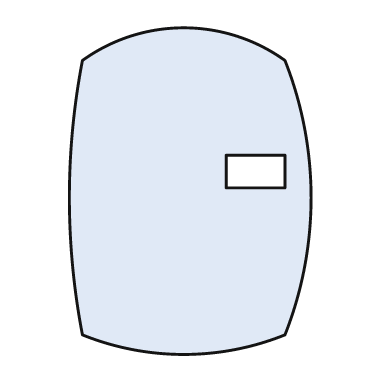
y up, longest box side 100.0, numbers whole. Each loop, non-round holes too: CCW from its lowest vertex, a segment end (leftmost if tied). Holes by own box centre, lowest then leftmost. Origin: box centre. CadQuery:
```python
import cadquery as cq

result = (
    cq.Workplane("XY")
    .moveTo(-33.0, -44.0)
    .threePointArc((-2.0, -50.0), (29.0, -44.0))
    .threePointArc((37.0, -2.0), (29.0, 40.0))
    .threePointArc((-2.0, 50.0), (-33.0, 40.0))
    .threePointArc((-37.0, -2.0), (-33.0, -44.0))
    .close()
    .moveTo(11.0, 1.0)
    .lineTo(29.0, 1.0)
    .lineTo(29.0, 11.0)
    .lineTo(11.0, 11.0)
    .close()
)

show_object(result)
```